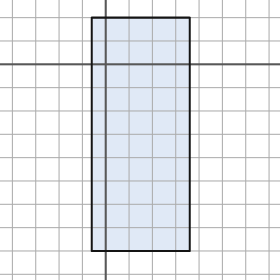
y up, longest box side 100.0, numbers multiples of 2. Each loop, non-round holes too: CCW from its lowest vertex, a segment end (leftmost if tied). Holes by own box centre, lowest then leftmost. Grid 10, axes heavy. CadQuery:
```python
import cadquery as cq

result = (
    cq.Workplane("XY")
    .moveTo(-6.0, -80.0)
    .lineTo(36.0, -80.0)
    .lineTo(36.0, 20.0)
    .lineTo(-6.0, 20.0)
    .close()
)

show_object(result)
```